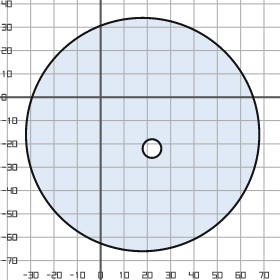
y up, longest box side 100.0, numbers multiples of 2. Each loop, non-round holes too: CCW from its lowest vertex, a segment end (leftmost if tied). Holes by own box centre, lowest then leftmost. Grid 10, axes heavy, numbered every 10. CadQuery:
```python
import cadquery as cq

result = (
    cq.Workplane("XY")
    .moveTo(18.0, -16.0)
    .circle(50.0)
    .moveTo(22.0, -22.0)
    .circle(4.0)
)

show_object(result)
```